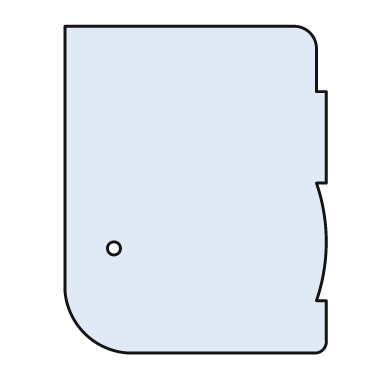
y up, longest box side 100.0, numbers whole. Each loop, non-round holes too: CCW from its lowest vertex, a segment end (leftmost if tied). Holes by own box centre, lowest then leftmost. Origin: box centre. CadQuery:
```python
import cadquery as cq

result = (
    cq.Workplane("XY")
    .moveTo(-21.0, -50.0)
    .lineTo(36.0, -50.0)
    .threePointArc((39.0, -49.0), (40.0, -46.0))
    .lineTo(40.0, -34.0)
    .lineTo(37.0, -34.0)
    .threePointArc((40.0, -16.0), (37.0, 2.0))
    .lineTo(40.0, 2.0)
    .lineTo(40.0, 30.0)
    .lineTo(37.0, 30.0)
    .lineTo(37.0, 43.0)
    .threePointArc((35.0, 48.0), (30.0, 50.0))
    .lineTo(-40.0, 50.0)
    .lineTo(-40.0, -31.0)
    .threePointArc((-34.0, -44.0), (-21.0, -50.0))
    .close()
    .moveTo(-25.0, -18.0)
    .circle(2.0)
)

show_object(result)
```